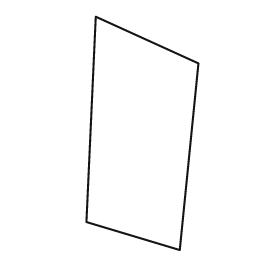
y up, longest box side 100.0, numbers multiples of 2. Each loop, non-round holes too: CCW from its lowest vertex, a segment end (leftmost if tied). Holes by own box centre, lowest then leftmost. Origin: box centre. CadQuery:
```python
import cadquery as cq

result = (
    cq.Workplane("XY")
    .moveTo(16.0, -50.0)
    .lineTo(24.0, 30.0)
    .lineTo(-20.0, 50.0)
    .lineTo(-24.0, -38.0)
    .close()
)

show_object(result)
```